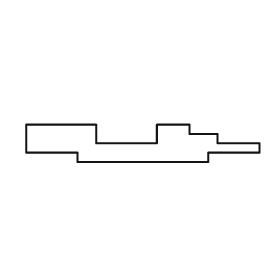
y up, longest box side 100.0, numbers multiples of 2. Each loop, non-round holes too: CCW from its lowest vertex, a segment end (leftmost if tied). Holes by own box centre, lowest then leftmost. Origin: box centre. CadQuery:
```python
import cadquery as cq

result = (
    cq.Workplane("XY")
    .moveTo(-28.0, -8.0)
    .lineTo(28.0, -8.0)
    .lineTo(28.0, -4.0)
    .lineTo(50.0, -4.0)
    .lineTo(50.0, 0.0)
    .lineTo(32.0, 0.0)
    .lineTo(32.0, 4.0)
    .lineTo(20.0, 4.0)
    .lineTo(20.0, 8.0)
    .lineTo(6.0, 8.0)
    .lineTo(6.0, 0.0)
    .lineTo(-20.0, 0.0)
    .lineTo(-20.0, 8.0)
    .lineTo(-50.0, 8.0)
    .lineTo(-50.0, -4.0)
    .lineTo(-28.0, -4.0)
    .close()
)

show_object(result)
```